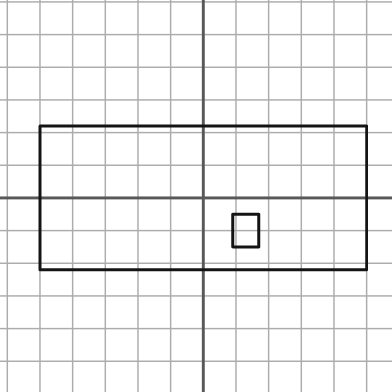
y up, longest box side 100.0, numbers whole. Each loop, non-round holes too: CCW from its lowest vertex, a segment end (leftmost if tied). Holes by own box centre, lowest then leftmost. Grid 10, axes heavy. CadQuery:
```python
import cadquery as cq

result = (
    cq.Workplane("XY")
    .moveTo(-50.0, -22.0)
    .lineTo(50.0, -22.0)
    .lineTo(50.0, 22.0)
    .lineTo(-50.0, 22.0)
    .close()
    .moveTo(9.0, -15.0)
    .lineTo(17.0, -15.0)
    .lineTo(17.0, -5.0)
    .lineTo(9.0, -5.0)
    .close()
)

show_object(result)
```